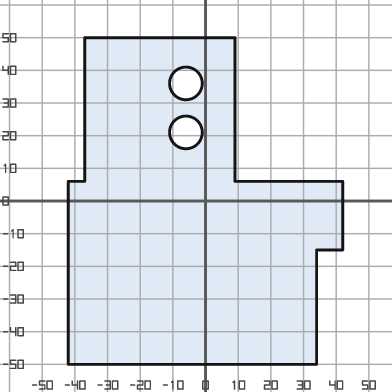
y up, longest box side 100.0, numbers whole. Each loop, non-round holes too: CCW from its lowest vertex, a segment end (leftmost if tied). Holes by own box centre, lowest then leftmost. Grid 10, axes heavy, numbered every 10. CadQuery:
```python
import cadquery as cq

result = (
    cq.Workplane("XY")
    .moveTo(-42.0, -50.0)
    .lineTo(34.0, -50.0)
    .lineTo(34.0, -15.0)
    .lineTo(42.0, -15.0)
    .lineTo(42.0, 6.0)
    .lineTo(9.0, 6.0)
    .lineTo(9.0, 50.0)
    .lineTo(-37.0, 50.0)
    .lineTo(-37.0, 6.0)
    .lineTo(-42.0, 6.0)
    .close()
    .moveTo(-6.0, 21.0)
    .circle(5.0)
    .moveTo(-6.0, 36.0)
    .circle(5.0)
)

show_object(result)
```